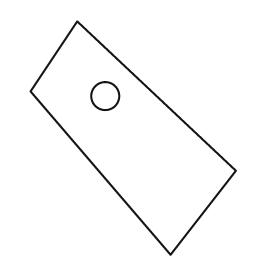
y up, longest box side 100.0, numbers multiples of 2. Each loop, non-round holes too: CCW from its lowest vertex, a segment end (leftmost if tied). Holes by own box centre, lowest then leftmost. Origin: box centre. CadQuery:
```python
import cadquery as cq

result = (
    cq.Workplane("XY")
    .moveTo(16.0, -50.0)
    .lineTo(44.0, -14.0)
    .lineTo(-24.0, 50.0)
    .lineTo(-44.0, 20.0)
    .close()
    .moveTo(-12.0, 18.0)
    .circle(6.0)
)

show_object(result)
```